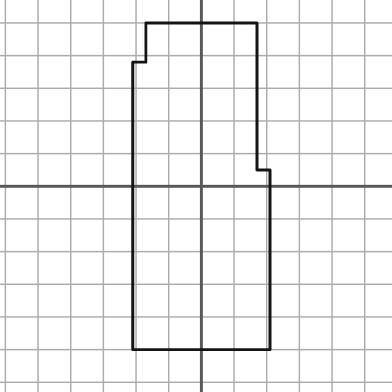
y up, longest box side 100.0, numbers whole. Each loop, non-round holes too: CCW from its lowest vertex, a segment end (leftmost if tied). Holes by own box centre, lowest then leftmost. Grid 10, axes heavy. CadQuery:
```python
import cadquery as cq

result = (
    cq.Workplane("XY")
    .moveTo(-21.0, -50.0)
    .lineTo(21.0, -50.0)
    .lineTo(21.0, 5.0)
    .lineTo(17.0, 5.0)
    .lineTo(17.0, 50.0)
    .lineTo(-17.0, 50.0)
    .lineTo(-17.0, 38.0)
    .lineTo(-21.0, 38.0)
    .close()
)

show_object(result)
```